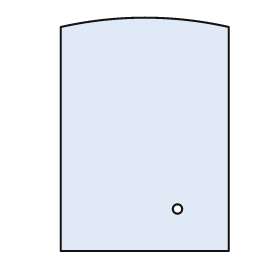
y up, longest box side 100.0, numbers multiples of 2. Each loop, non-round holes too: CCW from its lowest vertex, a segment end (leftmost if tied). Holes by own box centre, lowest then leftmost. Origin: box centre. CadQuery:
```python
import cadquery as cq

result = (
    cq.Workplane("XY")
    .moveTo(-36.0, -50.0)
    .lineTo(36.0, -50.0)
    .lineTo(36.0, 46.0)
    .threePointArc((0.0, 50.0), (-36.0, 46.0))
    .close()
    .moveTo(14.0, -32.0)
    .circle(2.0)
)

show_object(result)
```